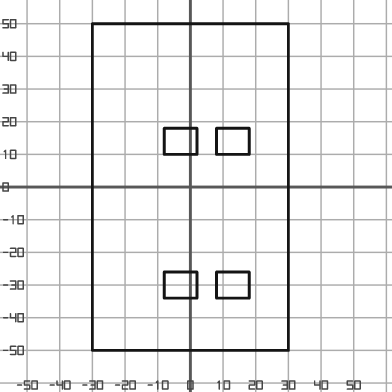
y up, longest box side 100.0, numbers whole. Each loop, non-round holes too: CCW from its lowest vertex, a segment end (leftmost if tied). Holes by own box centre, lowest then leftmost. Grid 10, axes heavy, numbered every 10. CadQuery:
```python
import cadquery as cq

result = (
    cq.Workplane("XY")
    .moveTo(-30.0, -50.0)
    .lineTo(30.0, -50.0)
    .lineTo(30.0, 50.0)
    .lineTo(-30.0, 50.0)
    .close()
    .moveTo(-8.0, -34.0)
    .lineTo(2.0, -34.0)
    .lineTo(2.0, -26.0)
    .lineTo(-8.0, -26.0)
    .close()
    .moveTo(8.0, -34.0)
    .lineTo(18.0, -34.0)
    .lineTo(18.0, -26.0)
    .lineTo(8.0, -26.0)
    .close()
    .moveTo(-8.0, 10.0)
    .lineTo(2.0, 10.0)
    .lineTo(2.0, 18.0)
    .lineTo(-8.0, 18.0)
    .close()
    .moveTo(8.0, 10.0)
    .lineTo(18.0, 10.0)
    .lineTo(18.0, 18.0)
    .lineTo(8.0, 18.0)
    .close()
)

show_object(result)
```